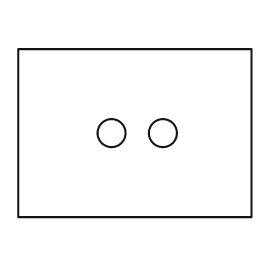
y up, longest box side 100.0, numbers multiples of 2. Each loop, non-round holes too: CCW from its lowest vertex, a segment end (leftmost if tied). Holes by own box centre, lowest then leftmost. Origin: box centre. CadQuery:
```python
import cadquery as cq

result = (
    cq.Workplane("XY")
    .moveTo(-50.0, -36.0)
    .lineTo(50.0, -36.0)
    .lineTo(50.0, 36.0)
    .lineTo(-50.0, 36.0)
    .close()
    .moveTo(-10.0, 0.0)
    .circle(6.0)
    .moveTo(12.0, 0.0)
    .circle(6.0)
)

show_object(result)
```